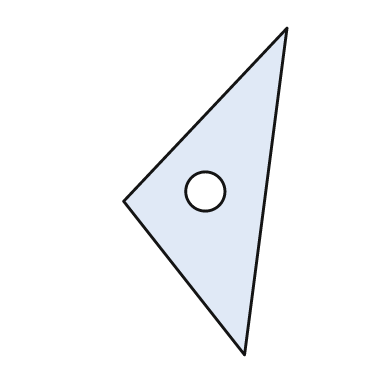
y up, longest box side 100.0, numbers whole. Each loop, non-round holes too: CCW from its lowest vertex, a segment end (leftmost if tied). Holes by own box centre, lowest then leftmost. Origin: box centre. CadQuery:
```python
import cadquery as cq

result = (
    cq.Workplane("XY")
    .moveTo(12.0, -50.0)
    .lineTo(25.0, 50.0)
    .lineTo(-25.0, -3.0)
    .close()
    .moveTo(0.0, 0.0)
    .circle(6.0)
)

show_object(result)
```